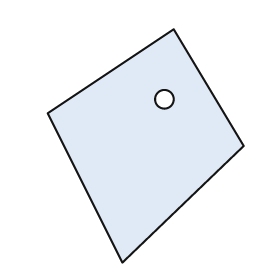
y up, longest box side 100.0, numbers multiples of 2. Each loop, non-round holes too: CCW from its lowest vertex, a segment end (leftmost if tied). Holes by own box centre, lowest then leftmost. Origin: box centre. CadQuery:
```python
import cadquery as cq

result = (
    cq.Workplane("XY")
    .moveTo(-10.0, -50.0)
    .lineTo(42.0, 0.0)
    .lineTo(12.0, 50.0)
    .lineTo(-42.0, 14.0)
    .close()
    .moveTo(8.0, 20.0)
    .circle(4.0)
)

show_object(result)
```